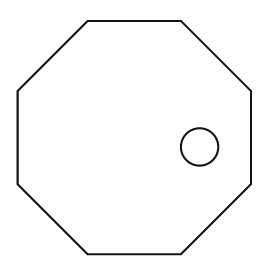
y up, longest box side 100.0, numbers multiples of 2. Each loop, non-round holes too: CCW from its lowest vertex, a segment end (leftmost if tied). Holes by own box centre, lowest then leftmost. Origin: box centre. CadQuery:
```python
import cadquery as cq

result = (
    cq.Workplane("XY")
    .moveTo(-20.0, -50.0)
    .lineTo(20.0, -50.0)
    .lineTo(50.0, -20.0)
    .lineTo(50.0, 20.0)
    .lineTo(20.0, 50.0)
    .lineTo(-20.0, 50.0)
    .lineTo(-50.0, 20.0)
    .lineTo(-50.0, -20.0)
    .close()
    .moveTo(28.0, -4.0)
    .circle(8.0)
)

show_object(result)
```